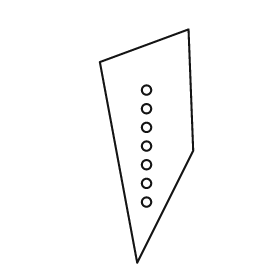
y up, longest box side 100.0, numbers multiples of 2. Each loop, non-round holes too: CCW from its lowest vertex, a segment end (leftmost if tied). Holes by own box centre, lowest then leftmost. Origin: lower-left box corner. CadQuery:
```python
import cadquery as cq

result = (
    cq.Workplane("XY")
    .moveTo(16.0, 0.0)
    .lineTo(40.0, 48.0)
    .lineTo(38.0, 100.0)
    .lineTo(0.0, 86.0)
    .close()
    .moveTo(20.0, 26.0)
    .circle(2.0)
    .moveTo(20.0, 34.0)
    .circle(2.0)
    .moveTo(20.0, 42.0)
    .circle(2.0)
    .moveTo(20.0, 50.0)
    .circle(2.0)
    .moveTo(20.0, 58.0)
    .circle(2.0)
    .moveTo(20.0, 66.0)
    .circle(2.0)
    .moveTo(20.0, 74.0)
    .circle(2.0)
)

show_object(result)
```